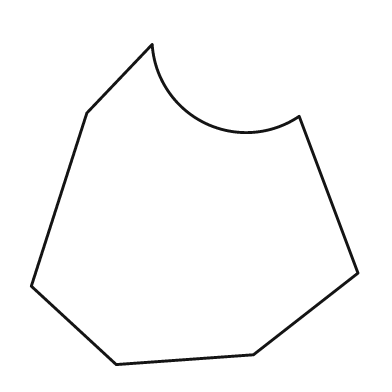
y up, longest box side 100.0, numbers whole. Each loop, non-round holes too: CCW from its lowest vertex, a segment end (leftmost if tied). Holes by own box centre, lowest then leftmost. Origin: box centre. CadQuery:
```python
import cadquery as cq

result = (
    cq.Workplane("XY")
    .moveTo(-24.0, -49.0)
    .lineTo(18.0, -46.0)
    .lineTo(50.0, -21.0)
    .lineTo(32.0, 27.0)
    .threePointArc((3.0, 25.0), (-13.0, 49.0))
    .lineTo(-33.0, 28.0)
    .lineTo(-50.0, -25.0)
    .close()
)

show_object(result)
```